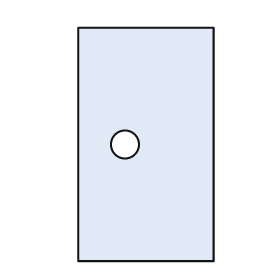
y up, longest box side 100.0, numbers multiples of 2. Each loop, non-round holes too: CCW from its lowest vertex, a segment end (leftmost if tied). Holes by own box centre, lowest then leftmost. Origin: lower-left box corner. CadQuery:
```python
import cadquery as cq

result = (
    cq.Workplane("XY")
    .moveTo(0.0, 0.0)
    .lineTo(58.0, 0.0)
    .lineTo(58.0, 100.0)
    .lineTo(0.0, 100.0)
    .close()
    .moveTo(20.0, 50.0)
    .circle(6.0)
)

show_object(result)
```